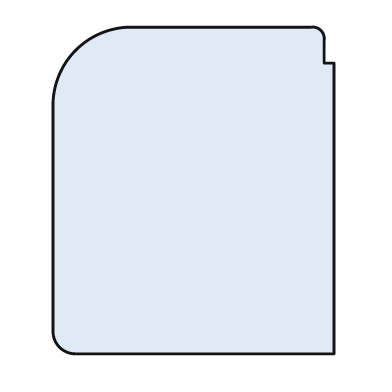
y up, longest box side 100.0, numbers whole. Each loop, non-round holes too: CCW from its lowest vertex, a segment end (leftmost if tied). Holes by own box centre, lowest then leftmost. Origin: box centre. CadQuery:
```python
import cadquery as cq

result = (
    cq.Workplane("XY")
    .moveTo(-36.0, -50.0)
    .lineTo(43.0, -50.0)
    .lineTo(43.0, 39.0)
    .lineTo(40.0, 39.0)
    .lineTo(40.0, 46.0)
    .threePointArc((39.0, 49.0), (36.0, 50.0))
    .lineTo(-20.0, 50.0)
    .threePointArc((-36.0, 43.0), (-43.0, 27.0))
    .lineTo(-43.0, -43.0)
    .threePointArc((-41.0, -48.0), (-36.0, -50.0))
    .close()
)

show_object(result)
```